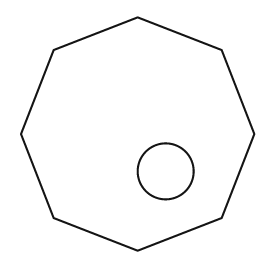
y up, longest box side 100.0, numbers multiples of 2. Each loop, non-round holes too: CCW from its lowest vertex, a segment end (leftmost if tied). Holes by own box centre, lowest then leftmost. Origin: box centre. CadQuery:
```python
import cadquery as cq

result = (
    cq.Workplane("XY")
    .moveTo(0.0, -50.0)
    .lineTo(36.0, -36.0)
    .lineTo(50.0, 0.0)
    .lineTo(36.0, 36.0)
    .lineTo(0.0, 50.0)
    .lineTo(-36.0, 36.0)
    .lineTo(-50.0, 0.0)
    .lineTo(-36.0, -36.0)
    .close()
    .moveTo(12.0, -16.0)
    .circle(12.0)
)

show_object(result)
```